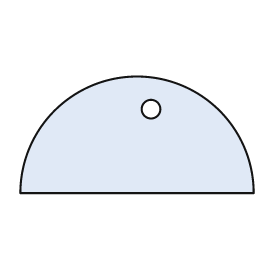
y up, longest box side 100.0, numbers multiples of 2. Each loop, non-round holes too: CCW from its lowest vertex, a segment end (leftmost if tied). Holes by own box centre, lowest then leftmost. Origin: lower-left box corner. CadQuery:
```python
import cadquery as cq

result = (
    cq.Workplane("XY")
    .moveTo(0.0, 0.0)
    .lineTo(100.0, 0.0)
    .threePointArc((50.0, 50.0), (0.0, 0.0))
    .close()
    .moveTo(56.0, 36.0)
    .circle(4.0)
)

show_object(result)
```